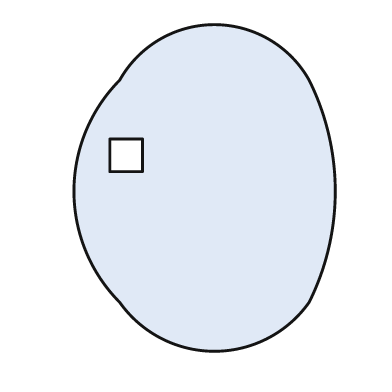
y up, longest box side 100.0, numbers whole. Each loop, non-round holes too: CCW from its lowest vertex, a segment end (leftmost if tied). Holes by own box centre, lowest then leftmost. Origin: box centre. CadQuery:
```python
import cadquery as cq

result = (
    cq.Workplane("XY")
    .moveTo(-26.0, -35.0)
    .threePointArc((3.0, -50.0), (32.0, -35.0))
    .threePointArc((40.0, -1.0), (32.0, 33.0))
    .threePointArc((3.0, 50.0), (-26.0, 33.0))
    .threePointArc((-40.0, -1.0), (-26.0, -35.0))
    .close()
    .moveTo(-29.0, 5.0)
    .lineTo(-19.0, 5.0)
    .lineTo(-19.0, 15.0)
    .lineTo(-29.0, 15.0)
    .close()
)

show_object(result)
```